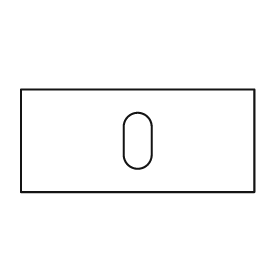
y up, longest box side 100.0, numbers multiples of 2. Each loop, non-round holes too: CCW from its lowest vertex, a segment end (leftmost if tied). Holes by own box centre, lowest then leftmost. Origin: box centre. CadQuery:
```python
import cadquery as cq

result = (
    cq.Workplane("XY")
    .moveTo(-50.0, -22.0)
    .lineTo(50.0, -22.0)
    .lineTo(50.0, 22.0)
    .lineTo(-50.0, 22.0)
    .close()
    .moveTo(-6.0, -6.0)
    .threePointArc((0.0, -12.0), (6.0, -6.0))
    .lineTo(6.0, 6.0)
    .threePointArc((0.0, 12.0), (-6.0, 6.0))
    .close()
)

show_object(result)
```